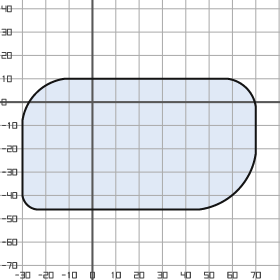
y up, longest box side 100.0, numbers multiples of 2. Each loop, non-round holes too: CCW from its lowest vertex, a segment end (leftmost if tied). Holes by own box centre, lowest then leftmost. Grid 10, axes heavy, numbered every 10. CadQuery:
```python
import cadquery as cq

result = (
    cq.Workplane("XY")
    .moveTo(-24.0, -46.0)
    .lineTo(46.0, -46.0)
    .threePointArc((62.0, -38.0), (70.0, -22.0))
    .lineTo(70.0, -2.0)
    .threePointArc((66.0, 6.0), (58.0, 10.0))
    .lineTo(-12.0, 10.0)
    .threePointArc((-24.0, 4.0), (-30.0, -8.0))
    .lineTo(-30.0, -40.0)
    .threePointArc((-28.0, -44.0), (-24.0, -46.0))
    .close()
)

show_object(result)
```